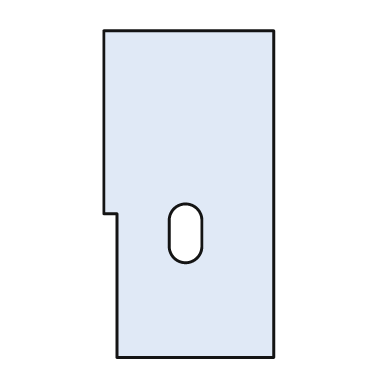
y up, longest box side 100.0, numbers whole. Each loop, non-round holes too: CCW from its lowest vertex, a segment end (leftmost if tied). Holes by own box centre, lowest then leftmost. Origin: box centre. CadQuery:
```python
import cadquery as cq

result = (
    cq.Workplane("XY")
    .moveTo(-22.0, -50.0)
    .lineTo(26.0, -50.0)
    .lineTo(26.0, 50.0)
    .lineTo(-26.0, 50.0)
    .lineTo(-26.0, -6.0)
    .lineTo(-22.0, -6.0)
    .close()
    .moveTo(-6.0, -16.0)
    .threePointArc((-1.0, -21.0), (4.0, -16.0))
    .lineTo(4.0, -8.0)
    .threePointArc((-1.0, -3.0), (-6.0, -8.0))
    .close()
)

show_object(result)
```